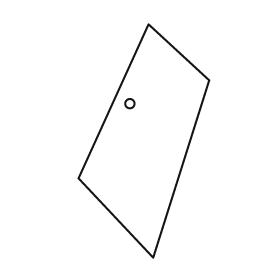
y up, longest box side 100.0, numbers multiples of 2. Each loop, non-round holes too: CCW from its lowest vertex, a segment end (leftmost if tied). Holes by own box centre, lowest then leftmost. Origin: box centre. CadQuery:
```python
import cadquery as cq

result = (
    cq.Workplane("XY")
    .moveTo(4.0, -50.0)
    .lineTo(28.0, 26.0)
    .lineTo(2.0, 50.0)
    .lineTo(-28.0, -16.0)
    .close()
    .moveTo(-6.0, 16.0)
    .circle(2.0)
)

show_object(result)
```